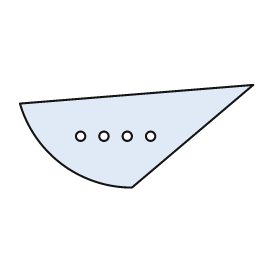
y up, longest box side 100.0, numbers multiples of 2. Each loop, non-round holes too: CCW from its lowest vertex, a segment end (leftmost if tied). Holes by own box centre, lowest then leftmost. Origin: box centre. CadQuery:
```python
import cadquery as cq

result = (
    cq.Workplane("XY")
    .moveTo(-2.0, -22.0)
    .lineTo(50.0, 22.0)
    .lineTo(-50.0, 14.0)
    .threePointArc((-32.0, -12.0), (-2.0, -22.0))
    .close()
    .moveTo(-24.0, 0.0)
    .circle(2.0)
    .moveTo(-14.0, 0.0)
    .circle(2.0)
    .moveTo(-4.0, 0.0)
    .circle(2.0)
    .moveTo(6.0, 0.0)
    .circle(2.0)
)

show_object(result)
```